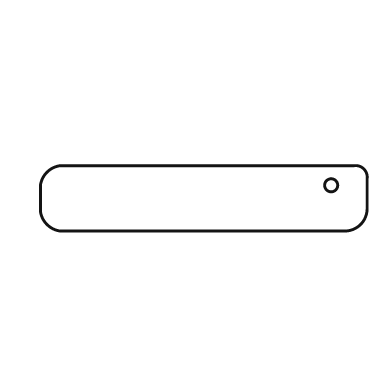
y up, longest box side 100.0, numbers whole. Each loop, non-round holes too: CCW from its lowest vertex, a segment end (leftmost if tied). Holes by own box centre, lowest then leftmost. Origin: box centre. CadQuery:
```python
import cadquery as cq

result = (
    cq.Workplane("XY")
    .moveTo(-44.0, -10.0)
    .lineTo(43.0, -10.0)
    .threePointArc((48.0, -8.0), (50.0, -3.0))
    .lineTo(50.0, 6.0)
    .threePointArc((49.0, 9.0), (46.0, 10.0))
    .lineTo(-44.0, 10.0)
    .threePointArc((-48.0, 8.0), (-50.0, 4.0))
    .lineTo(-50.0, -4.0)
    .threePointArc((-48.0, -8.0), (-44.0, -10.0))
    .close()
    .moveTo(39.0, 4.0)
    .circle(2.0)
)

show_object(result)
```